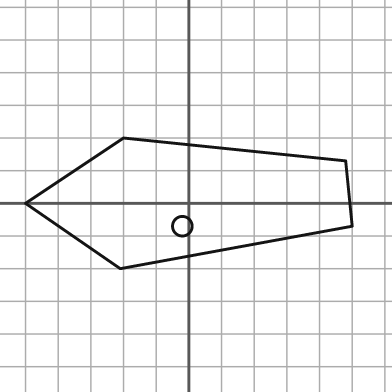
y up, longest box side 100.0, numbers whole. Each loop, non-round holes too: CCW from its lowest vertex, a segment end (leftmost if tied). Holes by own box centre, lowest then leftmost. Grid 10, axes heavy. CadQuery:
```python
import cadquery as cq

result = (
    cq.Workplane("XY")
    .moveTo(-21.0, -20.0)
    .lineTo(50.0, -7.0)
    .lineTo(48.0, 13.0)
    .lineTo(-20.0, 20.0)
    .lineTo(-50.0, 0.0)
    .close()
    .moveTo(-2.0, -7.0)
    .circle(3.0)
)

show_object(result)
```